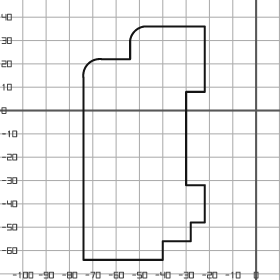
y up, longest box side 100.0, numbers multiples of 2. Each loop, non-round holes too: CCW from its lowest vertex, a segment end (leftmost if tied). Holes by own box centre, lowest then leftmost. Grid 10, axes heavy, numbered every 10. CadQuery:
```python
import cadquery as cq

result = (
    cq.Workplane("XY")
    .moveTo(-74.0, -64.0)
    .lineTo(-40.0, -64.0)
    .lineTo(-40.0, -56.0)
    .lineTo(-28.0, -56.0)
    .lineTo(-28.0, -48.0)
    .lineTo(-22.0, -48.0)
    .lineTo(-22.0, -32.0)
    .lineTo(-30.0, -32.0)
    .lineTo(-30.0, 8.0)
    .lineTo(-22.0, 8.0)
    .lineTo(-22.0, 36.0)
    .lineTo(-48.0, 36.0)
    .threePointArc((-52.0, 34.0), (-54.0, 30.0))
    .lineTo(-54.0, 22.0)
    .lineTo(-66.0, 22.0)
    .threePointArc((-72.0, 20.0), (-74.0, 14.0))
    .close()
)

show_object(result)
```